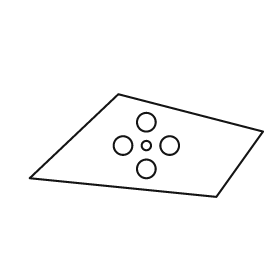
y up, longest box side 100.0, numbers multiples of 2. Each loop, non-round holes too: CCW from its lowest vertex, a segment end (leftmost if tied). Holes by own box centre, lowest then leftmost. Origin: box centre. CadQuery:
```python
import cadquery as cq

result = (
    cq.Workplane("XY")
    .moveTo(30.0, -22.0)
    .lineTo(50.0, 6.0)
    .lineTo(-12.0, 22.0)
    .lineTo(-50.0, -14.0)
    .close()
    .moveTo(0.0, -10.0)
    .circle(4.0)
    .moveTo(-10.0, 0.0)
    .circle(4.0)
    .moveTo(0.0, 0.0)
    .circle(2.0)
    .moveTo(10.0, 0.0)
    .circle(4.0)
    .moveTo(0.0, 10.0)
    .circle(4.0)
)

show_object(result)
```